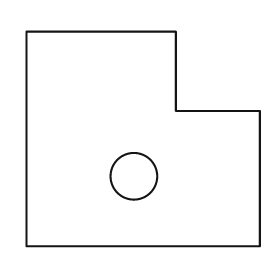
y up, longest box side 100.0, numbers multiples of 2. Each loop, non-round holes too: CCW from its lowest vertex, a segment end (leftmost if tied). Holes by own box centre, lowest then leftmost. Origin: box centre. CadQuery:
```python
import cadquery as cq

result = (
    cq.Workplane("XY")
    .moveTo(-50.0, -46.0)
    .lineTo(50.0, -46.0)
    .lineTo(50.0, 12.0)
    .lineTo(14.0, 12.0)
    .lineTo(14.0, 46.0)
    .lineTo(-50.0, 46.0)
    .close()
    .moveTo(-4.0, -16.0)
    .circle(10.0)
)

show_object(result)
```